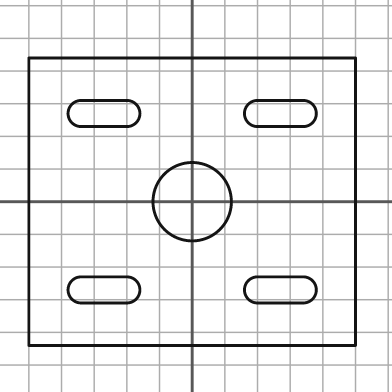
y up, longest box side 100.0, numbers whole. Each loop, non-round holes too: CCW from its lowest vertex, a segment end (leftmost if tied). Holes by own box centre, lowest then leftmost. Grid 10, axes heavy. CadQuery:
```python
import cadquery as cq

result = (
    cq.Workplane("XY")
    .moveTo(-50.0, -44.0)
    .lineTo(50.0, -44.0)
    .lineTo(50.0, 44.0)
    .lineTo(-50.0, 44.0)
    .close()
    .moveTo(-34.0, -31.0)
    .lineTo(-20.0, -31.0)
    .threePointArc((-16.0, -27.0), (-20.0, -23.0))
    .lineTo(-34.0, -23.0)
    .threePointArc((-38.0, -27.0), (-34.0, -31.0))
    .close()
    .moveTo(20.0, -31.0)
    .lineTo(34.0, -31.0)
    .threePointArc((38.0, -27.0), (34.0, -23.0))
    .lineTo(20.0, -23.0)
    .threePointArc((16.0, -27.0), (20.0, -31.0))
    .close()
    .moveTo(0.0, 0.0)
    .circle(12.0)
    .moveTo(-34.0, 23.0)
    .lineTo(-20.0, 23.0)
    .threePointArc((-16.0, 27.0), (-20.0, 31.0))
    .lineTo(-34.0, 31.0)
    .threePointArc((-38.0, 27.0), (-34.0, 23.0))
    .close()
    .moveTo(20.0, 23.0)
    .lineTo(34.0, 23.0)
    .threePointArc((38.0, 27.0), (34.0, 31.0))
    .lineTo(20.0, 31.0)
    .threePointArc((16.0, 27.0), (20.0, 23.0))
    .close()
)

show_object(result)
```